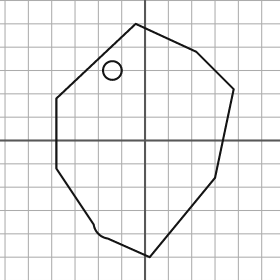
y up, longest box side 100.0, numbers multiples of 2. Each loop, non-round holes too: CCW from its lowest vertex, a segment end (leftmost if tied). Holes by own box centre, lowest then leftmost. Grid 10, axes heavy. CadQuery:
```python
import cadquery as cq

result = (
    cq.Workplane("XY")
    .moveTo(2.0, -50.0)
    .lineTo(30.0, -16.0)
    .lineTo(38.0, 22.0)
    .lineTo(22.0, 38.0)
    .lineTo(-4.0, 50.0)
    .lineTo(-38.0, 18.0)
    .lineTo(-38.0, -12.0)
    .lineTo(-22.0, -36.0)
    .threePointArc((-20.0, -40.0), (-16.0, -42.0))
    .close()
    .moveTo(-14.0, 30.0)
    .circle(4.0)
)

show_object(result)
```